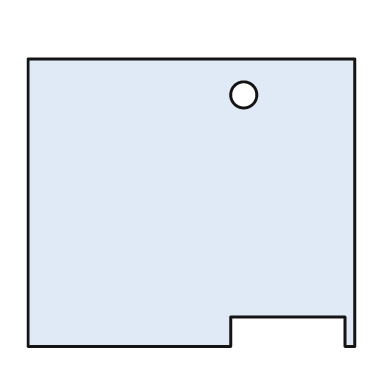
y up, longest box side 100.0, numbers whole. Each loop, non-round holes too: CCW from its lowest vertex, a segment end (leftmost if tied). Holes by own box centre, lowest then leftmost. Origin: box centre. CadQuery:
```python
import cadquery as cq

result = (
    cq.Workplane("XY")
    .moveTo(-50.0, -44.0)
    .lineTo(12.0, -44.0)
    .lineTo(12.0, -35.0)
    .lineTo(47.0, -35.0)
    .lineTo(47.0, -44.0)
    .lineTo(50.0, -44.0)
    .lineTo(50.0, 44.0)
    .lineTo(-50.0, 44.0)
    .close()
    .moveTo(16.0, 33.0)
    .circle(4.0)
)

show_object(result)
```